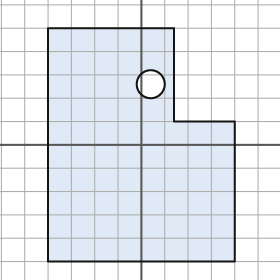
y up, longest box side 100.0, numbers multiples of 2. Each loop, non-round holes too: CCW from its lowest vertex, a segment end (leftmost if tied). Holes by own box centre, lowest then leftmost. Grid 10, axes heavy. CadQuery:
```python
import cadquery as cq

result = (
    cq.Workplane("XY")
    .moveTo(-40.0, -50.0)
    .lineTo(40.0, -50.0)
    .lineTo(40.0, 10.0)
    .lineTo(14.0, 10.0)
    .lineTo(14.0, 50.0)
    .lineTo(-40.0, 50.0)
    .close()
    .moveTo(4.0, 26.0)
    .circle(6.0)
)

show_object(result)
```